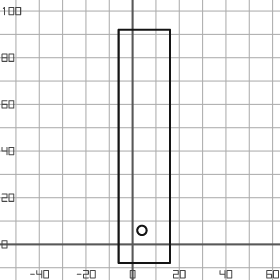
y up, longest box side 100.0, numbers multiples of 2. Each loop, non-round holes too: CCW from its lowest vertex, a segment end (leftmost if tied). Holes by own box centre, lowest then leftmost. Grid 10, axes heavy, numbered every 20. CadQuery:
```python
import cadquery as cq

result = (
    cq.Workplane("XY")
    .moveTo(-6.0, -8.0)
    .lineTo(16.0, -8.0)
    .lineTo(16.0, 92.0)
    .lineTo(-6.0, 92.0)
    .close()
    .moveTo(4.0, 6.0)
    .circle(2.0)
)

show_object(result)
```